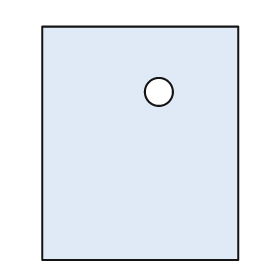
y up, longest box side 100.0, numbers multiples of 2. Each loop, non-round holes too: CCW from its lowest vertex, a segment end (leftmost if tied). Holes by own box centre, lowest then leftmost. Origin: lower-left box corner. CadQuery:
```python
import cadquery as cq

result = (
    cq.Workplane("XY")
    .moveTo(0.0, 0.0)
    .lineTo(84.0, 0.0)
    .lineTo(84.0, 100.0)
    .lineTo(0.0, 100.0)
    .close()
    .moveTo(50.0, 72.0)
    .circle(6.0)
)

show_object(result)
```